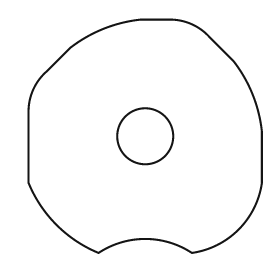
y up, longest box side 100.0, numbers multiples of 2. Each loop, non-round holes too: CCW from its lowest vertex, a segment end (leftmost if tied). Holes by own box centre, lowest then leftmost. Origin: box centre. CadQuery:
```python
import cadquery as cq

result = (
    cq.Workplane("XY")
    .moveTo(-20.0, -50.0)
    .threePointArc((0.0, -44.0), (20.0, -50.0))
    .threePointArc((40.0, -40.0), (50.0, -20.0))
    .lineTo(50.0, 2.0)
    .threePointArc((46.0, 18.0), (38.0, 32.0))
    .lineTo(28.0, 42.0)
    .threePointArc((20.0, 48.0), (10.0, 50.0))
    .lineTo(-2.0, 50.0)
    .threePointArc((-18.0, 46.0), (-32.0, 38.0))
    .lineTo(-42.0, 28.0)
    .threePointArc((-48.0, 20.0), (-50.0, 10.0))
    .lineTo(-50.0, -20.0)
    .threePointArc((-38.0, -38.0), (-20.0, -50.0))
    .close()
    .moveTo(0.0, 0.0)
    .circle(12.0)
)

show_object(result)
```